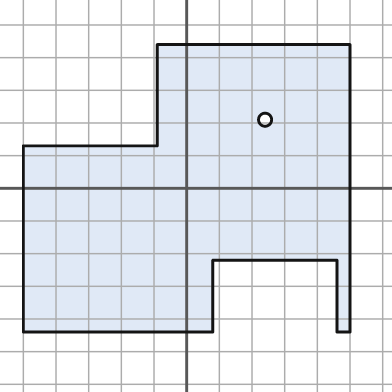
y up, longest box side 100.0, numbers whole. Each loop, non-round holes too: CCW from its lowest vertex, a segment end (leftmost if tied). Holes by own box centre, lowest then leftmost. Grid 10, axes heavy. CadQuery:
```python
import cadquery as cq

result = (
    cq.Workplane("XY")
    .moveTo(-50.0, -44.0)
    .lineTo(8.0, -44.0)
    .lineTo(8.0, -22.0)
    .lineTo(46.0, -22.0)
    .lineTo(46.0, -44.0)
    .lineTo(50.0, -44.0)
    .lineTo(50.0, 44.0)
    .lineTo(-9.0, 44.0)
    .lineTo(-9.0, 13.0)
    .lineTo(-50.0, 13.0)
    .close()
    .moveTo(24.0, 21.0)
    .circle(2.0)
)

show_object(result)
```